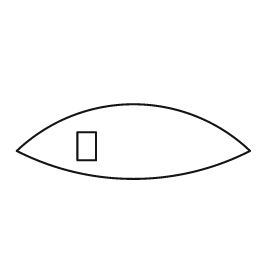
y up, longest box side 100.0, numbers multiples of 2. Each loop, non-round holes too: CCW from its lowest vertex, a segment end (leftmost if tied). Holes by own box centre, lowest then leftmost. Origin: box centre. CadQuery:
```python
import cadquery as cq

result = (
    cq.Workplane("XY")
    .moveTo(-50.0, -4.0)
    .threePointArc((0.0, -16.0), (50.0, -4.0))
    .threePointArc((0.0, 16.0), (-50.0, -4.0))
    .close()
    .moveTo(-24.0, -8.0)
    .lineTo(-16.0, -8.0)
    .lineTo(-16.0, 4.0)
    .lineTo(-24.0, 4.0)
    .close()
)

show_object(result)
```